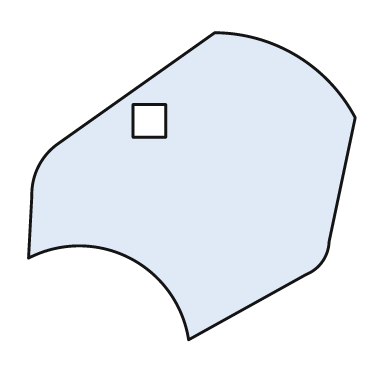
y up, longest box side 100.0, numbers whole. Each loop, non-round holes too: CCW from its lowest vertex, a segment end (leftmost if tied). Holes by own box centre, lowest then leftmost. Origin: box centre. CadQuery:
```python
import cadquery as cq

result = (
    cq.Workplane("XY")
    .moveTo(-1.0, -47.0)
    .lineTo(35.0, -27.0)
    .threePointArc((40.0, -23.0), (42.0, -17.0))
    .lineTo(50.0, 21.0)
    .threePointArc((32.0, 40.0), (7.0, 47.0))
    .lineTo(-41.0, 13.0)
    .threePointArc((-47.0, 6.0), (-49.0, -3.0))
    .lineTo(-50.0, -22.0)
    .threePointArc((-19.0, -22.0), (-1.0, -47.0))
    .close()
    .moveTo(-18.0, 15.0)
    .lineTo(-8.0, 15.0)
    .lineTo(-8.0, 25.0)
    .lineTo(-18.0, 25.0)
    .close()
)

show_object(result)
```